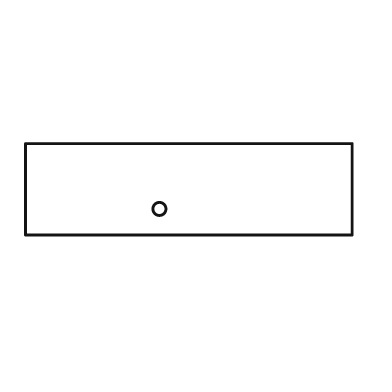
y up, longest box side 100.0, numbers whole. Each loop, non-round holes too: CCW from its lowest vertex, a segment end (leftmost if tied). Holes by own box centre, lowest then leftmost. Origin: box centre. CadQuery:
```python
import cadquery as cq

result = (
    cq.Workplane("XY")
    .moveTo(-50.0, -14.0)
    .lineTo(50.0, -14.0)
    .lineTo(50.0, 14.0)
    .lineTo(-50.0, 14.0)
    .close()
    .moveTo(-9.0, -6.0)
    .circle(2.0)
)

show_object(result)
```